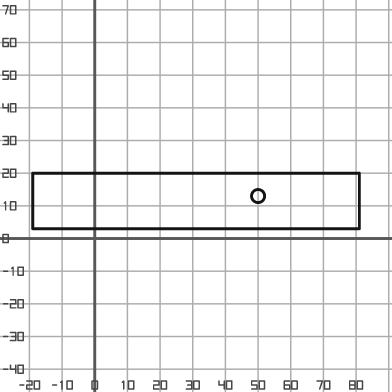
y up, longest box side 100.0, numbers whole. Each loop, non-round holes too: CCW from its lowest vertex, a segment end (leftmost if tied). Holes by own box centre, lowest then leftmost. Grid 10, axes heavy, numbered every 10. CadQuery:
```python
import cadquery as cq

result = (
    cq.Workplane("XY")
    .moveTo(-19.0, 3.0)
    .lineTo(81.0, 3.0)
    .lineTo(81.0, 20.0)
    .lineTo(-19.0, 20.0)
    .close()
    .moveTo(50.0, 13.0)
    .circle(2.0)
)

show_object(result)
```